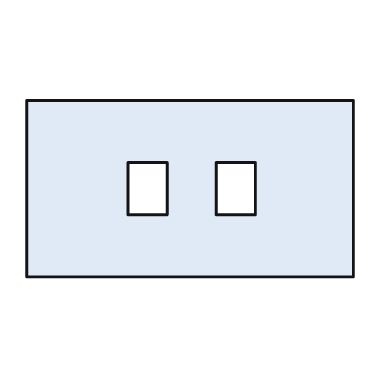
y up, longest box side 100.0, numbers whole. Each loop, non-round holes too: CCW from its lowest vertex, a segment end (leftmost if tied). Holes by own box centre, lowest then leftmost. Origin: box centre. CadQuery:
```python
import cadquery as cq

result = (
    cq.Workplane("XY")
    .moveTo(-50.0, -27.0)
    .lineTo(50.0, -27.0)
    .lineTo(50.0, 27.0)
    .lineTo(-50.0, 27.0)
    .close()
    .moveTo(-19.0, -8.0)
    .lineTo(-7.0, -8.0)
    .lineTo(-7.0, 8.0)
    .lineTo(-19.0, 8.0)
    .close()
    .moveTo(8.0, -8.0)
    .lineTo(20.0, -8.0)
    .lineTo(20.0, 8.0)
    .lineTo(8.0, 8.0)
    .close()
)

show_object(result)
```